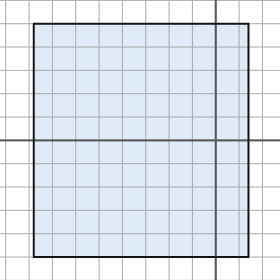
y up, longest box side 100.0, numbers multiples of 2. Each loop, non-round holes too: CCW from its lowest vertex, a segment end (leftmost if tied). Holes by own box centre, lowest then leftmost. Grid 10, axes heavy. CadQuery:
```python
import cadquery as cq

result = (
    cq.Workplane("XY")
    .moveTo(-78.0, -50.0)
    .lineTo(14.0, -50.0)
    .lineTo(14.0, 50.0)
    .lineTo(-78.0, 50.0)
    .close()
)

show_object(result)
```